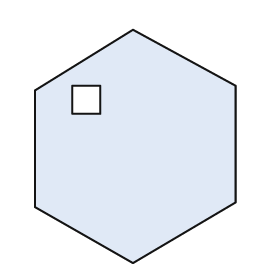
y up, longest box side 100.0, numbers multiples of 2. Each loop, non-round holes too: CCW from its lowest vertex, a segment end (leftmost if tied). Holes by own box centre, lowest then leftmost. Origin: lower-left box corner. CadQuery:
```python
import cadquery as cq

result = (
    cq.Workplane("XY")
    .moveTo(42.0, 0.0)
    .lineTo(86.0, 26.0)
    .lineTo(86.0, 76.0)
    .lineTo(42.0, 100.0)
    .lineTo(0.0, 74.0)
    .lineTo(0.0, 24.0)
    .close()
    .moveTo(16.0, 64.0)
    .lineTo(28.0, 64.0)
    .lineTo(28.0, 76.0)
    .lineTo(16.0, 76.0)
    .close()
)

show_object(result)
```